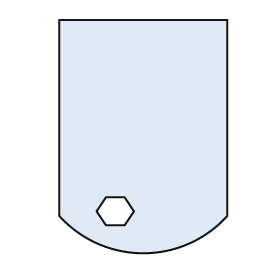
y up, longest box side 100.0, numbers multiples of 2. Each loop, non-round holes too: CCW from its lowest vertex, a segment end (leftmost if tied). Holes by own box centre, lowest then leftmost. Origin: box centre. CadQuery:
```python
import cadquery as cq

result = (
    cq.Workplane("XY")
    .moveTo(-36.0, -34.0)
    .threePointArc((0.0, -50.0), (36.0, -34.0))
    .lineTo(36.0, 50.0)
    .lineTo(-36.0, 50.0)
    .close()
    .moveTo(-16.0, -38.0)
    .lineTo(-8.0, -38.0)
    .lineTo(-4.0, -32.0)
    .lineTo(-8.0, -26.0)
    .lineTo(-16.0, -26.0)
    .lineTo(-20.0, -32.0)
    .close()
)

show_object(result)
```